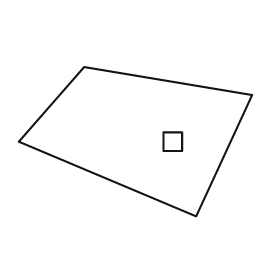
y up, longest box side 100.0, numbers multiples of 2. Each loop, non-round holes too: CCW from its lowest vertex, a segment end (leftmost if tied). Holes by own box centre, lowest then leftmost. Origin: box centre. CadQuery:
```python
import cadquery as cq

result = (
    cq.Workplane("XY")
    .moveTo(26.0, -32.0)
    .lineTo(50.0, 20.0)
    .lineTo(-22.0, 32.0)
    .lineTo(-50.0, 0.0)
    .close()
    .moveTo(12.0, -4.0)
    .lineTo(20.0, -4.0)
    .lineTo(20.0, 4.0)
    .lineTo(12.0, 4.0)
    .close()
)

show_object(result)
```